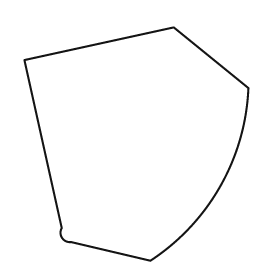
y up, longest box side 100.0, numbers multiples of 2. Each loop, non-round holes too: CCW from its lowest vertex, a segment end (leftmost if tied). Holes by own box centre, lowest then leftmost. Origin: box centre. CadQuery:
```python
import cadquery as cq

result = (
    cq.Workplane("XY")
    .moveTo(6.0, -50.0)
    .threePointArc((36.0, -18.0), (48.0, 24.0))
    .lineTo(16.0, 50.0)
    .lineTo(-48.0, 36.0)
    .lineTo(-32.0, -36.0)
    .threePointArc((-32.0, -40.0), (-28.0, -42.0))
    .close()
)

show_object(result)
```